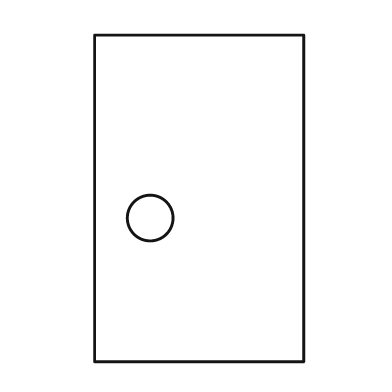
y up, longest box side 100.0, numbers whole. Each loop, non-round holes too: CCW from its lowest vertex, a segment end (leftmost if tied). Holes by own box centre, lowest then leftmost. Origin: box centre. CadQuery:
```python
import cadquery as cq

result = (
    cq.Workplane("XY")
    .moveTo(-32.0, -50.0)
    .lineTo(32.0, -50.0)
    .lineTo(32.0, 50.0)
    .lineTo(-32.0, 50.0)
    .close()
    .moveTo(-15.0, -6.0)
    .circle(7.0)
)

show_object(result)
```